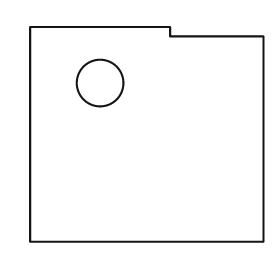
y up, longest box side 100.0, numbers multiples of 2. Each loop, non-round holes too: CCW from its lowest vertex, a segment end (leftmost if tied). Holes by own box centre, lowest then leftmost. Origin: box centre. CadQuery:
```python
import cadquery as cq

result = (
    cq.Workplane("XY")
    .moveTo(-50.0, -46.0)
    .lineTo(50.0, -46.0)
    .lineTo(50.0, 42.0)
    .lineTo(10.0, 42.0)
    .lineTo(10.0, 46.0)
    .lineTo(-50.0, 46.0)
    .close()
    .moveTo(-20.0, 22.0)
    .circle(10.0)
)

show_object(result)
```